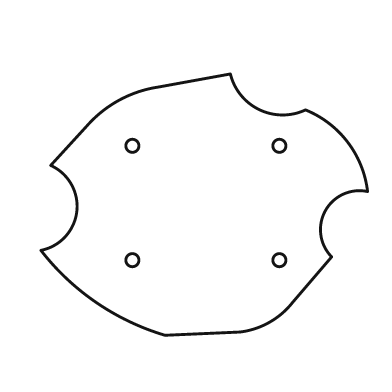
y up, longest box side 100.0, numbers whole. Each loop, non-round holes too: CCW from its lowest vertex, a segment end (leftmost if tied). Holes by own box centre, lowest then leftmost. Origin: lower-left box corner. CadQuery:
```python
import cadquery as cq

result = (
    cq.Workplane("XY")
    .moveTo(38.0, 0.0)
    .lineTo(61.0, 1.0)
    .threePointArc((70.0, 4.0), (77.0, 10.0))
    .lineTo(89.0, 24.0)
    .threePointArc((87.0, 38.0), (100.0, 44.0))
    .threePointArc((94.0, 59.0), (81.0, 69.0))
    .threePointArc((67.0, 69.0), (58.0, 80.0))
    .lineTo(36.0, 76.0)
    .threePointArc((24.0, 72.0), (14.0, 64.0))
    .lineTo(3.0, 52.0)
    .threePointArc((11.0, 38.0), (0.0, 26.0))
    .threePointArc((17.0, 10.0), (38.0, 0.0))
    .close()
    .moveTo(28.0, 23.0)
    .circle(2.0)
    .moveTo(73.0, 23.0)
    .circle(2.0)
    .moveTo(28.0, 58.0)
    .circle(2.0)
    .moveTo(73.0, 58.0)
    .circle(2.0)
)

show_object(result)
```